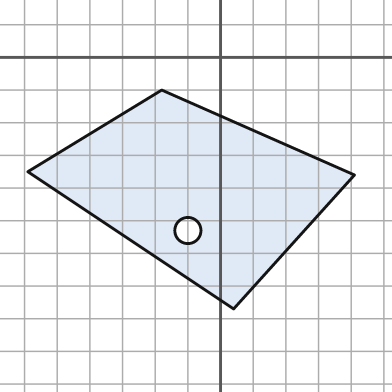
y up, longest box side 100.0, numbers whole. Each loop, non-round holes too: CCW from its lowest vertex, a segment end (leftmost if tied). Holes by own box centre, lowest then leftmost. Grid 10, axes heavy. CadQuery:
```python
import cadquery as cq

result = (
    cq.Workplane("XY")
    .moveTo(4.0, -77.0)
    .lineTo(41.0, -36.0)
    .lineTo(-18.0, -10.0)
    .lineTo(-59.0, -35.0)
    .close()
    .moveTo(-10.0, -53.0)
    .circle(4.0)
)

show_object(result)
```